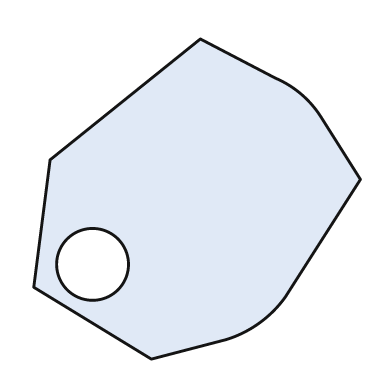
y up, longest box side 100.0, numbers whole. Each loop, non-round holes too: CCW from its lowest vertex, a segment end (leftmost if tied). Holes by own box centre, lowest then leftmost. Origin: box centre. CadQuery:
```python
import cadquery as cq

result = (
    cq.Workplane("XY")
    .moveTo(-14.0, -49.0)
    .lineTo(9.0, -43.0)
    .threePointArc((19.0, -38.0), (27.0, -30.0))
    .lineTo(50.0, 6.0)
    .lineTo(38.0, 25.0)
    .threePointArc((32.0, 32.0), (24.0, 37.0))
    .lineTo(1.0, 49.0)
    .lineTo(-45.0, 12.0)
    .lineTo(-50.0, -27.0)
    .close()
    .moveTo(-32.0, -20.0)
    .circle(11.0)
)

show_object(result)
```